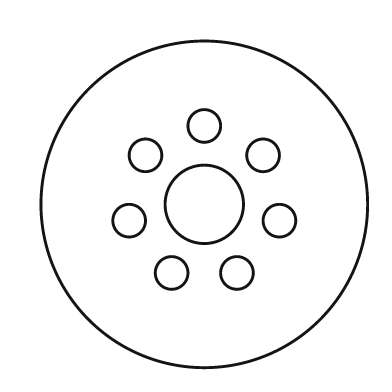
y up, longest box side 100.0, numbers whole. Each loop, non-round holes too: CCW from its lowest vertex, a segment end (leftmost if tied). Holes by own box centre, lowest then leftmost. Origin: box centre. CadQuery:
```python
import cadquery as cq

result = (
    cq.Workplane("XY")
    .moveTo(0.0, 0.0)
    .circle(50.0)
    .moveTo(-10.0, -21.0)
    .circle(5.0)
    .moveTo(10.0, -21.0)
    .circle(5.0)
    .moveTo(-23.0, -5.0)
    .circle(5.0)
    .moveTo(23.0, -5.0)
    .circle(5.0)
    .moveTo(0.0, 0.0)
    .circle(12.0)
    .moveTo(-18.0, 15.0)
    .circle(5.0)
    .moveTo(18.0, 15.0)
    .circle(5.0)
    .moveTo(0.0, 24.0)
    .circle(5.0)
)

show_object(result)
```